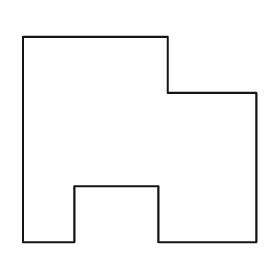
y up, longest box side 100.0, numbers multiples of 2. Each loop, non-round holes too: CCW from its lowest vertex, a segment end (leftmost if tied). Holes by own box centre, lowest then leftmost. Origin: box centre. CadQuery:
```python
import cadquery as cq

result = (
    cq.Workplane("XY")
    .moveTo(-50.0, -44.0)
    .lineTo(-28.0, -44.0)
    .lineTo(-28.0, -20.0)
    .lineTo(8.0, -20.0)
    .lineTo(8.0, -44.0)
    .lineTo(50.0, -44.0)
    .lineTo(50.0, 20.0)
    .lineTo(12.0, 20.0)
    .lineTo(12.0, 44.0)
    .lineTo(-50.0, 44.0)
    .close()
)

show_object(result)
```